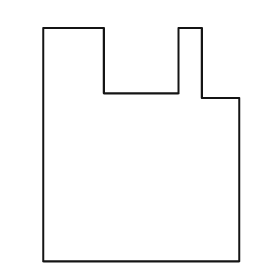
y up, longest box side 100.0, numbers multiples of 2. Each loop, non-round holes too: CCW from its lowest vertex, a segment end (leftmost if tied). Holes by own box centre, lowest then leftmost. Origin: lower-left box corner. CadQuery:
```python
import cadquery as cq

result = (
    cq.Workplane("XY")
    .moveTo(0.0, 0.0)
    .lineTo(84.0, 0.0)
    .lineTo(84.0, 70.0)
    .lineTo(68.0, 70.0)
    .lineTo(68.0, 100.0)
    .lineTo(58.0, 100.0)
    .lineTo(58.0, 72.0)
    .lineTo(26.0, 72.0)
    .lineTo(26.0, 100.0)
    .lineTo(0.0, 100.0)
    .close()
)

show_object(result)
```